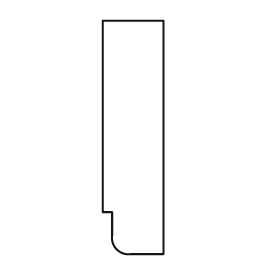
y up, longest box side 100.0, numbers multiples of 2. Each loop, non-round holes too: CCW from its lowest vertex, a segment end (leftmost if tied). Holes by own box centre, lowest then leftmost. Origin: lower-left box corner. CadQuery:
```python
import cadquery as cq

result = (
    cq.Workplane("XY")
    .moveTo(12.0, 0.0)
    .lineTo(26.0, 0.0)
    .lineTo(26.0, 100.0)
    .lineTo(0.0, 100.0)
    .lineTo(0.0, 18.0)
    .lineTo(4.0, 18.0)
    .lineTo(4.0, 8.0)
    .threePointArc((6.0, 2.0), (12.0, 0.0))
    .close()
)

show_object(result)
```